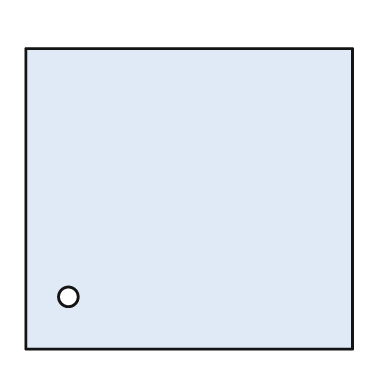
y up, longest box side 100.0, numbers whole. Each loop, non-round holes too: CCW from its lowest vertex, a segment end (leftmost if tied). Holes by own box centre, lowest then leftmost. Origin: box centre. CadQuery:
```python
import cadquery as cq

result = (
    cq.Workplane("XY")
    .moveTo(-50.0, -46.0)
    .lineTo(50.0, -46.0)
    .lineTo(50.0, 46.0)
    .lineTo(-50.0, 46.0)
    .close()
    .moveTo(-37.0, -30.0)
    .circle(3.0)
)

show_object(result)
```